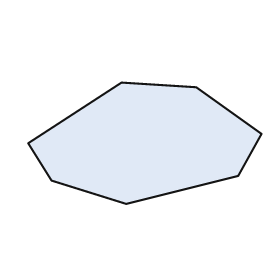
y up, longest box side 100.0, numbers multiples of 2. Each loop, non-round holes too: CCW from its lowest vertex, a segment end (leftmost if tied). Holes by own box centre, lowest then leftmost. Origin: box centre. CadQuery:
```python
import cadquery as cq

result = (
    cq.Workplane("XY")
    .moveTo(-8.0, -26.0)
    .lineTo(40.0, -14.0)
    .lineTo(50.0, 4.0)
    .lineTo(22.0, 24.0)
    .lineTo(-10.0, 26.0)
    .lineTo(-50.0, 0.0)
    .lineTo(-40.0, -16.0)
    .close()
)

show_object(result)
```